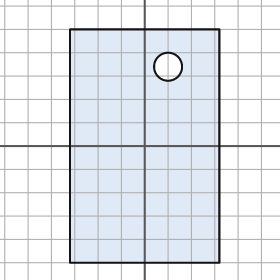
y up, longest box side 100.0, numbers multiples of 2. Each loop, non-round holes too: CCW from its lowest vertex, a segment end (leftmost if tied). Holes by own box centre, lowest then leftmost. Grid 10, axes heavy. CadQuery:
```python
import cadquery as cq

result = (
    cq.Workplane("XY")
    .moveTo(-32.0, -50.0)
    .lineTo(32.0, -50.0)
    .lineTo(32.0, 50.0)
    .lineTo(-32.0, 50.0)
    .close()
    .moveTo(10.0, 34.0)
    .circle(6.0)
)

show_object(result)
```